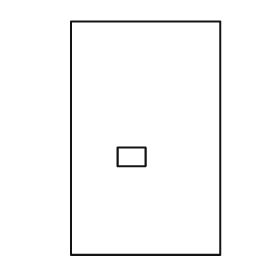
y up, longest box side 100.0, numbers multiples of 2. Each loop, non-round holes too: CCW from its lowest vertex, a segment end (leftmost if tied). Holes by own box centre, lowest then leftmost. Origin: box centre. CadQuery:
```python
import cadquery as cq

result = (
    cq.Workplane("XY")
    .moveTo(-32.0, -50.0)
    .lineTo(32.0, -50.0)
    .lineTo(32.0, 50.0)
    .lineTo(-32.0, 50.0)
    .close()
    .moveTo(-12.0, -12.0)
    .lineTo(0.0, -12.0)
    .lineTo(0.0, -4.0)
    .lineTo(-12.0, -4.0)
    .close()
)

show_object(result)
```